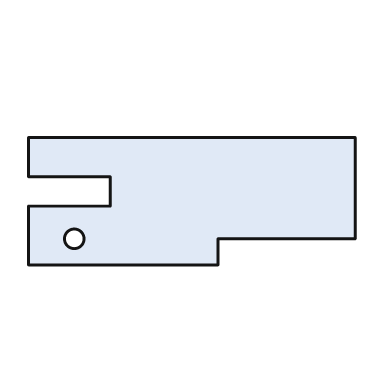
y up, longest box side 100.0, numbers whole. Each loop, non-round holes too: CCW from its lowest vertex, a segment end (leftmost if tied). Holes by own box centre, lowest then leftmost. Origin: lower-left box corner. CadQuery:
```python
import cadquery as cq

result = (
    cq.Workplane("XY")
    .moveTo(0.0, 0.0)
    .lineTo(58.0, 0.0)
    .lineTo(58.0, 8.0)
    .lineTo(100.0, 8.0)
    .lineTo(100.0, 39.0)
    .lineTo(0.0, 39.0)
    .lineTo(0.0, 27.0)
    .lineTo(25.0, 27.0)
    .lineTo(25.0, 18.0)
    .lineTo(0.0, 18.0)
    .close()
    .moveTo(14.0, 8.0)
    .circle(3.0)
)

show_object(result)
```